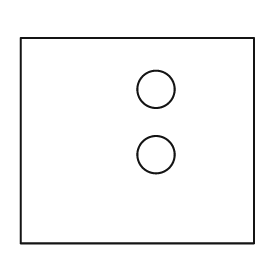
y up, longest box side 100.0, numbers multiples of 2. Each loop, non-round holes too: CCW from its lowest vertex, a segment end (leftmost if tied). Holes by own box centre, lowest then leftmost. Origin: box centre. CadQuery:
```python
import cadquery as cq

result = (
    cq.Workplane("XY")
    .moveTo(-50.0, -44.0)
    .lineTo(50.0, -44.0)
    .lineTo(50.0, 44.0)
    .lineTo(-50.0, 44.0)
    .close()
    .moveTo(8.0, -6.0)
    .circle(8.0)
    .moveTo(8.0, 22.0)
    .circle(8.0)
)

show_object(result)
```